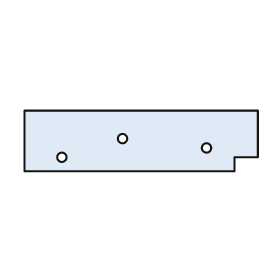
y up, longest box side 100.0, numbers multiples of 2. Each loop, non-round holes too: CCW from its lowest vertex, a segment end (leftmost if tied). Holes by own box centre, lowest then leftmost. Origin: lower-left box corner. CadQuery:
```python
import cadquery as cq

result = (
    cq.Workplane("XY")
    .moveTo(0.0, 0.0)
    .lineTo(90.0, 0.0)
    .lineTo(90.0, 6.0)
    .lineTo(100.0, 6.0)
    .lineTo(100.0, 26.0)
    .lineTo(0.0, 26.0)
    .close()
    .moveTo(16.0, 6.0)
    .circle(2.0)
    .moveTo(78.0, 10.0)
    .circle(2.0)
    .moveTo(42.0, 14.0)
    .circle(2.0)
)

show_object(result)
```